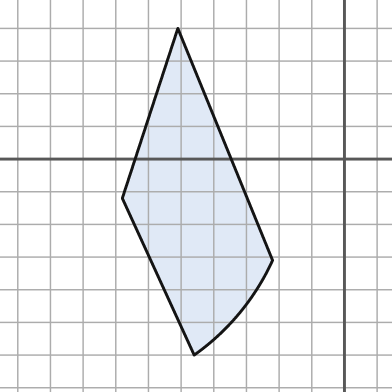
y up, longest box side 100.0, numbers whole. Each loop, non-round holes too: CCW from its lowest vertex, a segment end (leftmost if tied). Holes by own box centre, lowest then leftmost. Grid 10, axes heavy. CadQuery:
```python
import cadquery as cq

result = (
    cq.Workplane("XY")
    .moveTo(-46.0, -60.0)
    .threePointArc((-32.0, -47.0), (-22.0, -31.0))
    .lineTo(-51.0, 40.0)
    .lineTo(-68.0, -12.0)
    .close()
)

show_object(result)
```